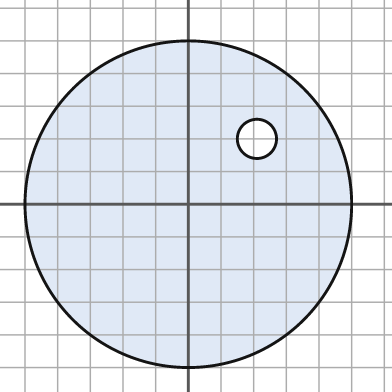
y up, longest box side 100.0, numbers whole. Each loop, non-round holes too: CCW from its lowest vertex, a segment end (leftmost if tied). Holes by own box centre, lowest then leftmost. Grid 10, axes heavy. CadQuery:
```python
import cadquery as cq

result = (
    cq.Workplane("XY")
    .moveTo(0.0, 0.0)
    .circle(50.0)
    .moveTo(21.0, 20.0)
    .circle(6.0)
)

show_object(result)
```